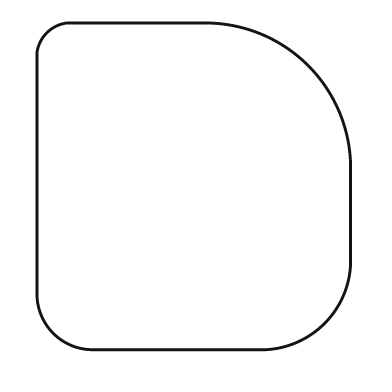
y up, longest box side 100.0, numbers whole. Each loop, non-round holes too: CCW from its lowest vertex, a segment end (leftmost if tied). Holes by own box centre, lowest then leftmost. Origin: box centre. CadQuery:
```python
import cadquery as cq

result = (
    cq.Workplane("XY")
    .moveTo(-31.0, -50.0)
    .lineTo(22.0, -50.0)
    .threePointArc((40.0, -42.0), (48.0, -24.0))
    .lineTo(48.0, 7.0)
    .threePointArc((35.0, 37.0), (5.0, 50.0))
    .lineTo(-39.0, 50.0)
    .threePointArc((-45.0, 47.0), (-48.0, 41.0))
    .lineTo(-48.0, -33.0)
    .threePointArc((-43.0, -45.0), (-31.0, -50.0))
    .close()
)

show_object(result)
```